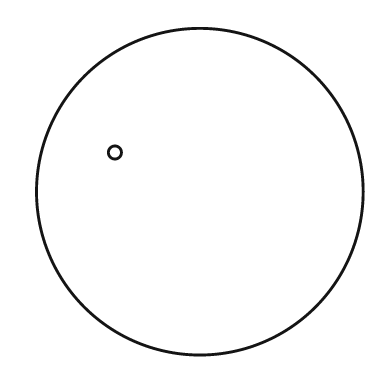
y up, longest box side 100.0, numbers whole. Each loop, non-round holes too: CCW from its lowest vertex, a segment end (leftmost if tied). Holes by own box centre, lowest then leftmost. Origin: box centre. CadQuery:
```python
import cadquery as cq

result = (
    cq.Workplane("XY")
    .moveTo(0.0, 0.0)
    .circle(50.0)
    .moveTo(-26.0, 12.0)
    .circle(2.0)
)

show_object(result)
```